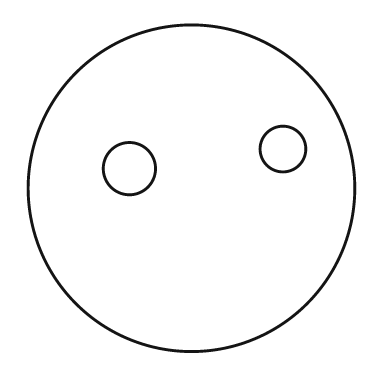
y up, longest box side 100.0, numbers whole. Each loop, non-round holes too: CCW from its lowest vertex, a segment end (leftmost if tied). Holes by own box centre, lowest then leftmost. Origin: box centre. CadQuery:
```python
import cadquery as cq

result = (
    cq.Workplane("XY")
    .moveTo(0.0, 0.0)
    .circle(50.0)
    .moveTo(-19.0, 6.0)
    .circle(8.0)
    .moveTo(28.0, 12.0)
    .circle(7.0)
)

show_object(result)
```